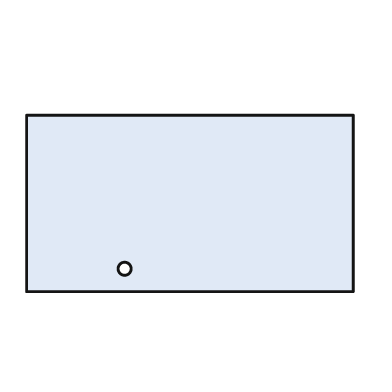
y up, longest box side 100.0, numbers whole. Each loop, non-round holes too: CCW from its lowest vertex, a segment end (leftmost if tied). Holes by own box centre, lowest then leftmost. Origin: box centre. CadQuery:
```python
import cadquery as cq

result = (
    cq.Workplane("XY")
    .moveTo(-50.0, -27.0)
    .lineTo(50.0, -27.0)
    .lineTo(50.0, 27.0)
    .lineTo(-50.0, 27.0)
    .close()
    .moveTo(-20.0, -20.0)
    .circle(2.0)
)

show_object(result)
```